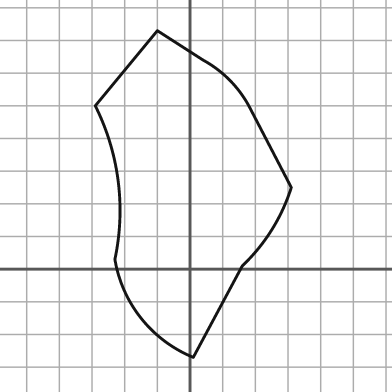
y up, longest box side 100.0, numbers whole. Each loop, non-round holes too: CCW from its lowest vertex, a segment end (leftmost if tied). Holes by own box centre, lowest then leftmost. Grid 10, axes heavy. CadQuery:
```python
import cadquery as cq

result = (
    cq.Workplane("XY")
    .moveTo(1.0, -27.0)
    .lineTo(16.0, 1.0)
    .threePointArc((25.0, 12.0), (31.0, 25.0))
    .lineTo(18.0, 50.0)
    .threePointArc((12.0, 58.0), (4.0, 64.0))
    .lineTo(-10.0, 73.0)
    .lineTo(-29.0, 50.0)
    .threePointArc((-22.0, 27.0), (-23.0, 3.0))
    .threePointArc((-15.0, -15.0), (1.0, -27.0))
    .close()
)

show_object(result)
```